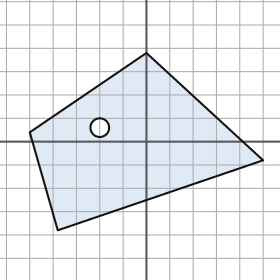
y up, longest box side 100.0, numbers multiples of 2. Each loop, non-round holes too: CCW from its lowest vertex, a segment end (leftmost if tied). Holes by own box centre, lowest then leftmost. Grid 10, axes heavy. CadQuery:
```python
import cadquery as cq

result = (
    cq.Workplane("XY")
    .moveTo(-38.0, -38.0)
    .lineTo(50.0, -8.0)
    .lineTo(0.0, 38.0)
    .lineTo(-50.0, 4.0)
    .close()
    .moveTo(-20.0, 6.0)
    .circle(4.0)
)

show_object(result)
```